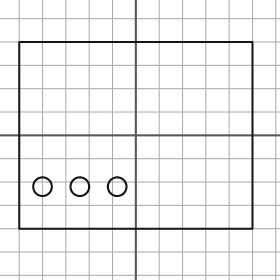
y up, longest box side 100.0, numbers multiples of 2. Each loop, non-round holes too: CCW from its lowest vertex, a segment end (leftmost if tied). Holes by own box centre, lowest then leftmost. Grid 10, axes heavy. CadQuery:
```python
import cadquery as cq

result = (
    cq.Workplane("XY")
    .moveTo(-50.0, -40.0)
    .lineTo(50.0, -40.0)
    .lineTo(50.0, 40.0)
    .lineTo(-50.0, 40.0)
    .close()
    .moveTo(-40.0, -22.0)
    .circle(4.0)
    .moveTo(-24.0, -22.0)
    .circle(4.0)
    .moveTo(-8.0, -22.0)
    .circle(4.0)
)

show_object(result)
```